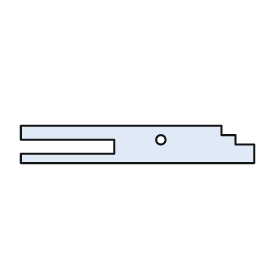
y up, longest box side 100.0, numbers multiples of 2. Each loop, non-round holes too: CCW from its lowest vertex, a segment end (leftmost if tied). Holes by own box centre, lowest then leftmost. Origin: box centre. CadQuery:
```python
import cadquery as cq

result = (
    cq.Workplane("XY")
    .moveTo(-50.0, -8.0)
    .lineTo(50.0, -8.0)
    .lineTo(50.0, 0.0)
    .lineTo(42.0, 0.0)
    .lineTo(42.0, 4.0)
    .lineTo(36.0, 4.0)
    .lineTo(36.0, 8.0)
    .lineTo(-50.0, 8.0)
    .lineTo(-50.0, 2.0)
    .lineTo(-10.0, 2.0)
    .lineTo(-10.0, -4.0)
    .lineTo(-50.0, -4.0)
    .close()
    .moveTo(10.0, 2.0)
    .circle(2.0)
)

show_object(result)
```